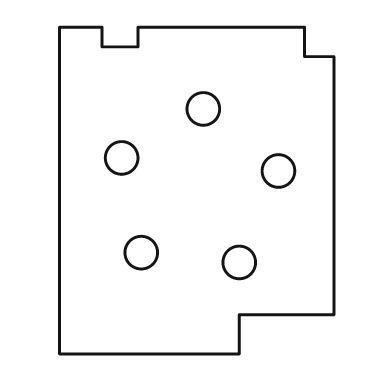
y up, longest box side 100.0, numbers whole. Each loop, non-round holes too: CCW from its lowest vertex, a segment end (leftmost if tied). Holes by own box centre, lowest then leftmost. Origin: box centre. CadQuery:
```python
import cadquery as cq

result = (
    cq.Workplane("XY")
    .moveTo(-42.0, -50.0)
    .lineTo(13.0, -50.0)
    .lineTo(13.0, -38.0)
    .lineTo(42.0, -38.0)
    .lineTo(42.0, 41.0)
    .lineTo(33.0, 41.0)
    .lineTo(33.0, 50.0)
    .lineTo(-18.0, 50.0)
    .lineTo(-18.0, 44.0)
    .lineTo(-29.0, 44.0)
    .lineTo(-29.0, 50.0)
    .lineTo(-42.0, 50.0)
    .close()
    .moveTo(13.0, -22.0)
    .circle(5.0)
    .moveTo(-17.0, -19.0)
    .circle(5.0)
    .moveTo(25.0, 6.0)
    .circle(5.0)
    .moveTo(-23.0, 10.0)
    .circle(5.0)
    .moveTo(2.0, 25.0)
    .circle(5.0)
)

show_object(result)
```